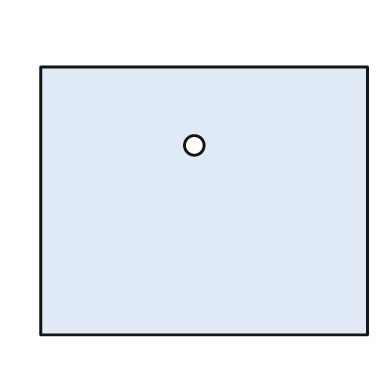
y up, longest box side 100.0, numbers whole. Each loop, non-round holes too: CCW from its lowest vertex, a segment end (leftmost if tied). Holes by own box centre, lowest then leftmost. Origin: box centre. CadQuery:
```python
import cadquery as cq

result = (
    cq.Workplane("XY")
    .moveTo(-50.0, -41.0)
    .lineTo(50.0, -41.0)
    .lineTo(50.0, 41.0)
    .lineTo(-50.0, 41.0)
    .close()
    .moveTo(-3.0, 17.0)
    .circle(3.0)
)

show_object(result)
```